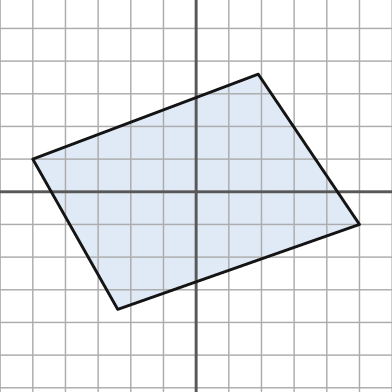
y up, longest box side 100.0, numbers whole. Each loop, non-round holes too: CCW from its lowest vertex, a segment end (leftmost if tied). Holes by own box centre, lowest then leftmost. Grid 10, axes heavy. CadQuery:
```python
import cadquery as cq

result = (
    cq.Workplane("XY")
    .moveTo(-24.0, -36.0)
    .lineTo(50.0, -10.0)
    .lineTo(19.0, 36.0)
    .lineTo(-50.0, 10.0)
    .close()
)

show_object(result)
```